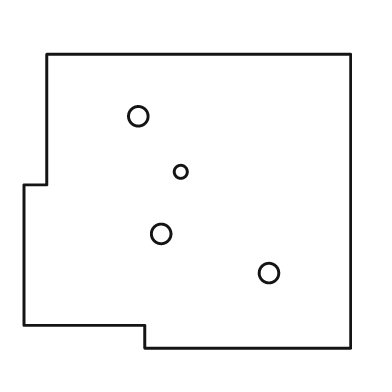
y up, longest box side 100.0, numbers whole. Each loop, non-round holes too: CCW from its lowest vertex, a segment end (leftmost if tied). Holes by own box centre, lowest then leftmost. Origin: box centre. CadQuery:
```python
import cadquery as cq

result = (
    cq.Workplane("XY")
    .moveTo(-13.0, -45.0)
    .lineTo(50.0, -45.0)
    .lineTo(50.0, 45.0)
    .lineTo(-43.0, 45.0)
    .lineTo(-43.0, 5.0)
    .lineTo(-50.0, 5.0)
    .lineTo(-50.0, -38.0)
    .lineTo(-13.0, -38.0)
    .close()
    .moveTo(25.0, -22.0)
    .circle(3.0)
    .moveTo(-8.0, -10.0)
    .circle(3.0)
    .moveTo(-2.0, 9.0)
    .circle(2.0)
    .moveTo(-15.0, 26.0)
    .circle(3.0)
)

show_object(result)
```